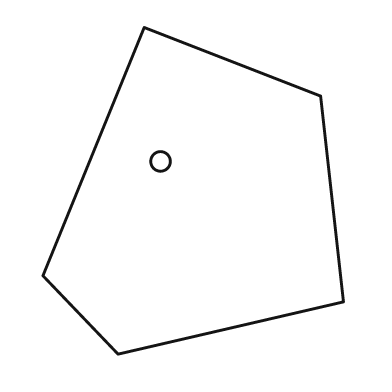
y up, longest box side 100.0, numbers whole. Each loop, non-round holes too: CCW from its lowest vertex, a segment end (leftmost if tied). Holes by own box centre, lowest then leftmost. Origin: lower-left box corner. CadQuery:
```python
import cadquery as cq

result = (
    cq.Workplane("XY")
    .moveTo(23.0, 0.0)
    .lineTo(92.0, 16.0)
    .lineTo(85.0, 79.0)
    .lineTo(31.0, 100.0)
    .lineTo(0.0, 24.0)
    .close()
    .moveTo(36.0, 59.0)
    .circle(3.0)
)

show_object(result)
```